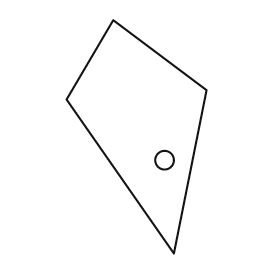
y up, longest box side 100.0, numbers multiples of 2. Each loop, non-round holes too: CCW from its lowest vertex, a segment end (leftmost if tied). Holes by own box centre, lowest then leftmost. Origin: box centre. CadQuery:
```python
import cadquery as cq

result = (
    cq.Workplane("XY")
    .moveTo(16.0, -50.0)
    .lineTo(30.0, 20.0)
    .lineTo(-10.0, 50.0)
    .lineTo(-30.0, 16.0)
    .close()
    .moveTo(12.0, -10.0)
    .circle(4.0)
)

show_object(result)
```